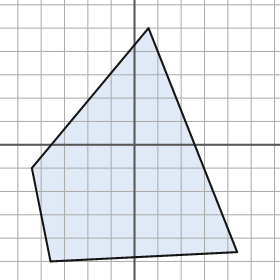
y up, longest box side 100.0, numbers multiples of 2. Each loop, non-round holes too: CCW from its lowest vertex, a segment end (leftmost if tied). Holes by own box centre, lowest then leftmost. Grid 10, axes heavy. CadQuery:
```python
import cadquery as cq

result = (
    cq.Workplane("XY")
    .moveTo(-36.0, -50.0)
    .lineTo(44.0, -46.0)
    .lineTo(6.0, 50.0)
    .lineTo(-44.0, -10.0)
    .close()
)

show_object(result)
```